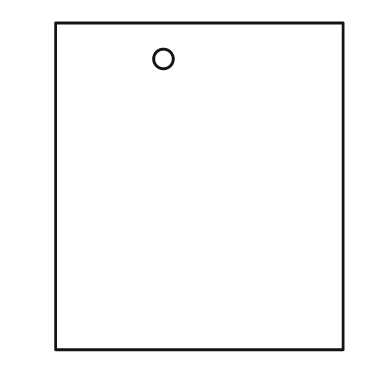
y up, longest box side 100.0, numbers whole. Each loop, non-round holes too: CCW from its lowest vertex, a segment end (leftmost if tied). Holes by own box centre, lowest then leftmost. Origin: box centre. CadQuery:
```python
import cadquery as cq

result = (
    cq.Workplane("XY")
    .moveTo(-44.0, -50.0)
    .lineTo(44.0, -50.0)
    .lineTo(44.0, 50.0)
    .lineTo(-44.0, 50.0)
    .close()
    .moveTo(-11.0, 39.0)
    .circle(3.0)
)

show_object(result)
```